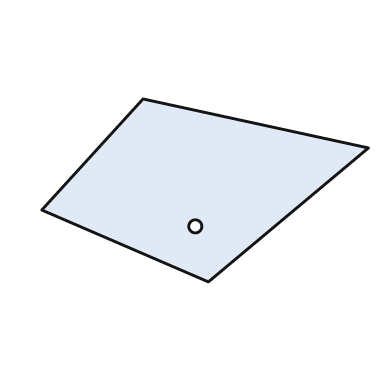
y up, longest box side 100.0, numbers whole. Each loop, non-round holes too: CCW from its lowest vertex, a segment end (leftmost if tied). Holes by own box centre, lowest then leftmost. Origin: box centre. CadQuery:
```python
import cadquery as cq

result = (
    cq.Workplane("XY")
    .moveTo(1.0, -28.0)
    .lineTo(50.0, 13.0)
    .lineTo(-19.0, 28.0)
    .lineTo(-50.0, -6.0)
    .close()
    .moveTo(-3.0, -11.0)
    .circle(2.0)
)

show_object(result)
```